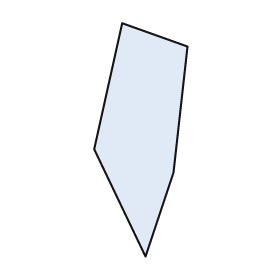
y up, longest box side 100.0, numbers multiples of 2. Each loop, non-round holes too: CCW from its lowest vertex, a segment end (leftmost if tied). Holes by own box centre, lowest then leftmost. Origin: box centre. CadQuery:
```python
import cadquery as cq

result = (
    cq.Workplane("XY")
    .moveTo(2.0, -50.0)
    .lineTo(14.0, -14.0)
    .lineTo(20.0, 40.0)
    .lineTo(-8.0, 50.0)
    .lineTo(-20.0, -4.0)
    .close()
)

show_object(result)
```